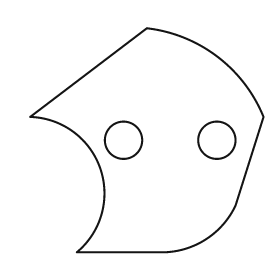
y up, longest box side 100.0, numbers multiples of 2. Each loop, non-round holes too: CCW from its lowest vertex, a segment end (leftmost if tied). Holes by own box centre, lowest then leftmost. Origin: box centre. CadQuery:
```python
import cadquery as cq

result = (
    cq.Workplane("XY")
    .moveTo(-30.0, -48.0)
    .lineTo(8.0, -48.0)
    .threePointArc((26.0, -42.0), (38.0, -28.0))
    .lineTo(50.0, 10.0)
    .threePointArc((30.0, 36.0), (0.0, 48.0))
    .lineTo(-50.0, 10.0)
    .threePointArc((-20.0, -12.0), (-30.0, -48.0))
    .close()
    .moveTo(-10.0, 0.0)
    .circle(8.0)
    .moveTo(30.0, 0.0)
    .circle(8.0)
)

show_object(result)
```